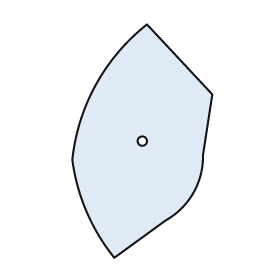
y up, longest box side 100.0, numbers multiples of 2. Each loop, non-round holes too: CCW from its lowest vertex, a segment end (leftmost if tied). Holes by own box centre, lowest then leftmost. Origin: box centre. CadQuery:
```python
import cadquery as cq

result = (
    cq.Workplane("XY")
    .moveTo(-12.0, -50.0)
    .lineTo(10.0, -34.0)
    .threePointArc((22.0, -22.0), (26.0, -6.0))
    .lineTo(30.0, 20.0)
    .lineTo(2.0, 50.0)
    .threePointArc((-20.0, 24.0), (-30.0, -8.0))
    .threePointArc((-24.0, -30.0), (-12.0, -50.0))
    .close()
    .moveTo(0.0, 0.0)
    .circle(2.0)
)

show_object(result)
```